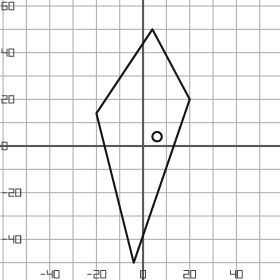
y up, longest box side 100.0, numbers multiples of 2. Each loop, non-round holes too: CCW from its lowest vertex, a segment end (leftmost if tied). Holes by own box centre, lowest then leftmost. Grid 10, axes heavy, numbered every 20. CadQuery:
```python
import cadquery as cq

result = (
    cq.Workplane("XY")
    .moveTo(-4.0, -50.0)
    .lineTo(20.0, 20.0)
    .lineTo(4.0, 50.0)
    .lineTo(-20.0, 14.0)
    .close()
    .moveTo(6.0, 4.0)
    .circle(2.0)
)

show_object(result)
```